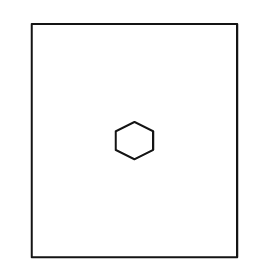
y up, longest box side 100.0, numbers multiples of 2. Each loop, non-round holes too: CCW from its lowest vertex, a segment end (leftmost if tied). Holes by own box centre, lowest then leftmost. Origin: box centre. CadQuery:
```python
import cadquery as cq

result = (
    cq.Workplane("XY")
    .moveTo(-44.0, -50.0)
    .lineTo(44.0, -50.0)
    .lineTo(44.0, 50.0)
    .lineTo(-44.0, 50.0)
    .close()
    .moveTo(0.0, -8.0)
    .lineTo(8.0, -4.0)
    .lineTo(8.0, 4.0)
    .lineTo(0.0, 8.0)
    .lineTo(-8.0, 4.0)
    .lineTo(-8.0, -4.0)
    .close()
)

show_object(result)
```